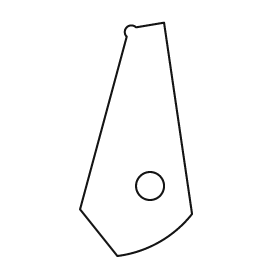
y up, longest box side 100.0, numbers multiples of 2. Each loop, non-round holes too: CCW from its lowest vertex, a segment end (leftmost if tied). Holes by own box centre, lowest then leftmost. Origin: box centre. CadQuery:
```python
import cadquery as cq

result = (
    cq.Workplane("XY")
    .moveTo(-8.0, -50.0)
    .threePointArc((10.0, -44.0), (24.0, -32.0))
    .lineTo(12.0, 50.0)
    .lineTo(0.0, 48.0)
    .threePointArc((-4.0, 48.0), (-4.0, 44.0))
    .lineTo(-24.0, -30.0)
    .close()
    .moveTo(6.0, -20.0)
    .circle(6.0)
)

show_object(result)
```